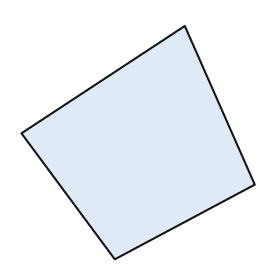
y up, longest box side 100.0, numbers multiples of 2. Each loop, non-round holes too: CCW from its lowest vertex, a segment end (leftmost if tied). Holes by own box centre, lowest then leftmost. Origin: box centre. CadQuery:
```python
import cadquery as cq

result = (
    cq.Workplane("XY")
    .moveTo(-10.0, -50.0)
    .lineTo(50.0, -18.0)
    .lineTo(20.0, 50.0)
    .lineTo(-50.0, 4.0)
    .close()
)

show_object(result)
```